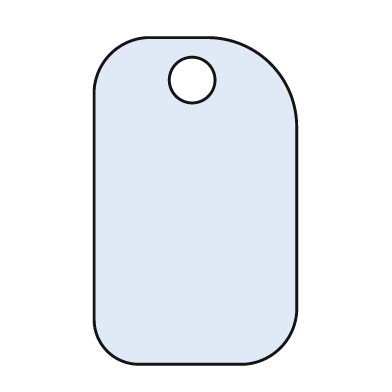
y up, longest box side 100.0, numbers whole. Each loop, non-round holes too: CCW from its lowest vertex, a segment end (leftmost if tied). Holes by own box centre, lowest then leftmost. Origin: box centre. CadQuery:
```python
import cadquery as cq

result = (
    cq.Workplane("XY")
    .moveTo(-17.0, -50.0)
    .lineTo(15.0, -50.0)
    .threePointArc((26.0, -45.0), (31.0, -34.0))
    .lineTo(31.0, 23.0)
    .threePointArc((23.0, 42.0), (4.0, 50.0))
    .lineTo(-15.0, 50.0)
    .threePointArc((-26.0, 45.0), (-31.0, 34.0))
    .lineTo(-31.0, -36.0)
    .threePointArc((-27.0, -46.0), (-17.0, -50.0))
    .close()
    .moveTo(-1.0, 37.0)
    .circle(7.0)
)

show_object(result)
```